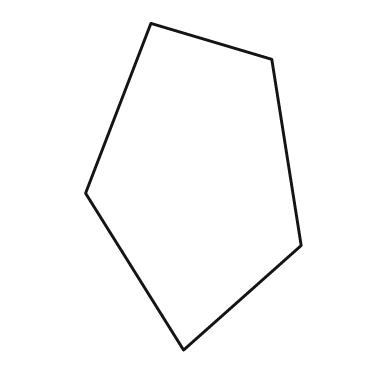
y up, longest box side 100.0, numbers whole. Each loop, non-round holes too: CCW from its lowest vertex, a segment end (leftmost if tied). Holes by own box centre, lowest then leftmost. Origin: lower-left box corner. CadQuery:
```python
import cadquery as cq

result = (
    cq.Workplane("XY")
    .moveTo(30.0, 0.0)
    .lineTo(66.0, 32.0)
    .lineTo(57.0, 89.0)
    .lineTo(20.0, 100.0)
    .lineTo(0.0, 48.0)
    .close()
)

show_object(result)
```